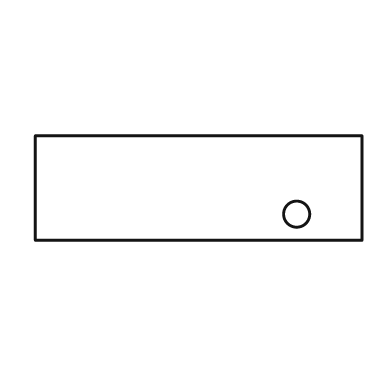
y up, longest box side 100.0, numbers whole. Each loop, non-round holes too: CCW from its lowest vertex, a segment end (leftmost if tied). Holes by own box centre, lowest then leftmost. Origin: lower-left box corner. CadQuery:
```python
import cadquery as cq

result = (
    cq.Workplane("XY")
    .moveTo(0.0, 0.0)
    .lineTo(100.0, 0.0)
    .lineTo(100.0, 32.0)
    .lineTo(0.0, 32.0)
    .close()
    .moveTo(80.0, 8.0)
    .circle(4.0)
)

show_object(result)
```